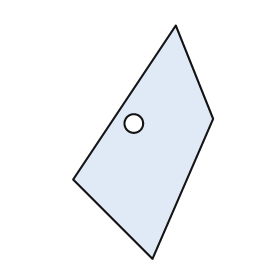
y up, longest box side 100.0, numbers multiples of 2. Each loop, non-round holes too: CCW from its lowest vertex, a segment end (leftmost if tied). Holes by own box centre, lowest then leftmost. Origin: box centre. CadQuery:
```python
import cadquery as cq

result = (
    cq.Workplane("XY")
    .moveTo(4.0, -50.0)
    .lineTo(30.0, 10.0)
    .lineTo(14.0, 50.0)
    .lineTo(-30.0, -16.0)
    .close()
    .moveTo(-4.0, 8.0)
    .circle(4.0)
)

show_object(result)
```